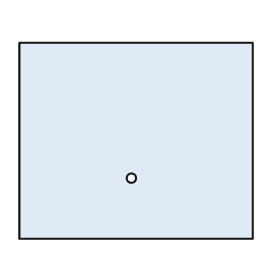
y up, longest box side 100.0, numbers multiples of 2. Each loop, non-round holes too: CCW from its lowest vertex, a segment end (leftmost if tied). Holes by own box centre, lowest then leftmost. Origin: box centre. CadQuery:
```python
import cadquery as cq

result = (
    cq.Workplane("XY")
    .moveTo(-50.0, -42.0)
    .lineTo(50.0, -42.0)
    .lineTo(50.0, 42.0)
    .lineTo(-50.0, 42.0)
    .close()
    .moveTo(-2.0, -16.0)
    .circle(2.0)
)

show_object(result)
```